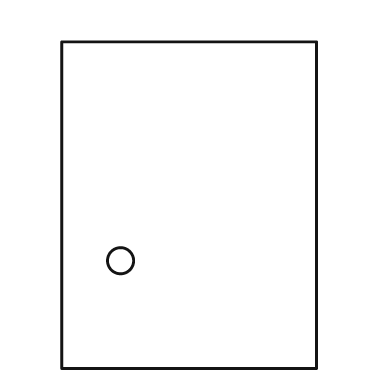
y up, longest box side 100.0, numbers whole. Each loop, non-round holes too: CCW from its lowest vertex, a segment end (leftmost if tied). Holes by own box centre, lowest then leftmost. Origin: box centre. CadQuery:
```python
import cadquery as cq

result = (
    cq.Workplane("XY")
    .moveTo(-39.0, -50.0)
    .lineTo(39.0, -50.0)
    .lineTo(39.0, 50.0)
    .lineTo(-39.0, 50.0)
    .close()
    .moveTo(-21.0, -17.0)
    .circle(4.0)
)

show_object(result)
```